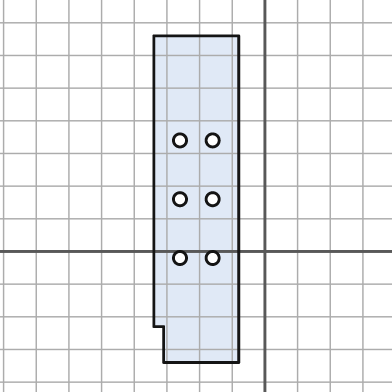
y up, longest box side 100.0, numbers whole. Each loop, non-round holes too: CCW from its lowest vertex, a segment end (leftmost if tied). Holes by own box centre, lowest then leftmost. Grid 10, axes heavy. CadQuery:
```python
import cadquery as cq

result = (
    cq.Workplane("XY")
    .moveTo(-31.0, -34.0)
    .lineTo(-8.0, -34.0)
    .lineTo(-8.0, 66.0)
    .lineTo(-34.0, 66.0)
    .lineTo(-34.0, -23.0)
    .lineTo(-31.0, -23.0)
    .close()
    .moveTo(-26.0, -2.0)
    .circle(2.0)
    .moveTo(-16.0, -2.0)
    .circle(2.0)
    .moveTo(-26.0, 16.0)
    .circle(2.0)
    .moveTo(-16.0, 16.0)
    .circle(2.0)
    .moveTo(-26.0, 34.0)
    .circle(2.0)
    .moveTo(-16.0, 34.0)
    .circle(2.0)
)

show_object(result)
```